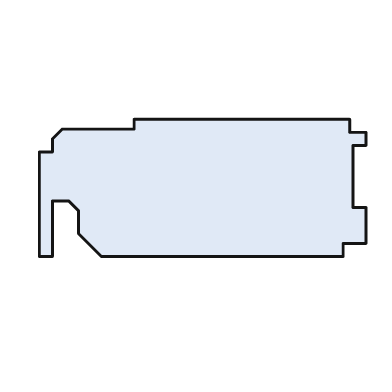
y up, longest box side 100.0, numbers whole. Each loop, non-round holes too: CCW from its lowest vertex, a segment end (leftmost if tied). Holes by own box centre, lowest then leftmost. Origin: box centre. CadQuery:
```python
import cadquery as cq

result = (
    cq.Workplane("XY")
    .moveTo(-50.0, -21.0)
    .lineTo(-46.0, -21.0)
    .lineTo(-46.0, -4.0)
    .lineTo(-41.0, -4.0)
    .lineTo(-38.0, -7.0)
    .lineTo(-38.0, -14.0)
    .lineTo(-31.0, -21.0)
    .lineTo(43.0, -21.0)
    .lineTo(43.0, -17.0)
    .lineTo(50.0, -17.0)
    .lineTo(50.0, -6.0)
    .lineTo(46.0, -6.0)
    .lineTo(46.0, 13.0)
    .lineTo(50.0, 13.0)
    .lineTo(50.0, 17.0)
    .lineTo(45.0, 17.0)
    .lineTo(45.0, 21.0)
    .lineTo(-21.0, 21.0)
    .lineTo(-21.0, 18.0)
    .lineTo(-43.0, 18.0)
    .lineTo(-46.0, 15.0)
    .lineTo(-46.0, 11.0)
    .lineTo(-50.0, 11.0)
    .close()
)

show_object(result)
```